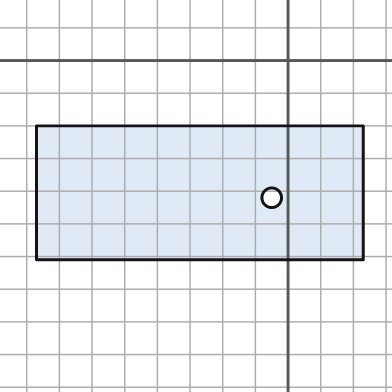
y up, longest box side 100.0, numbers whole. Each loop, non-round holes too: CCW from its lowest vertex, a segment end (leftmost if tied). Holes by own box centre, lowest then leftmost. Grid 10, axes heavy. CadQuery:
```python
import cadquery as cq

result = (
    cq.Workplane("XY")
    .moveTo(-77.0, -61.0)
    .lineTo(23.0, -61.0)
    .lineTo(23.0, -20.0)
    .lineTo(-77.0, -20.0)
    .close()
    .moveTo(-5.0, -42.0)
    .circle(3.0)
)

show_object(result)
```